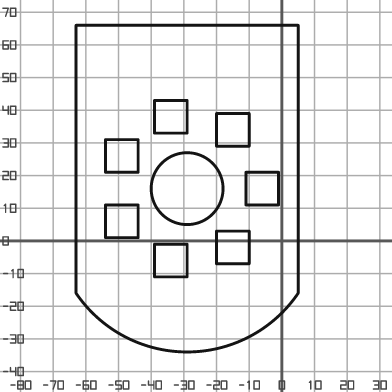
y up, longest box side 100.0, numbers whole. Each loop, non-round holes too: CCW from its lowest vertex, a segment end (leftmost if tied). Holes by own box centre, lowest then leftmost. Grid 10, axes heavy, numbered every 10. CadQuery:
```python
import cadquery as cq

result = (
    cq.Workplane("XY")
    .moveTo(-63.0, -16.0)
    .threePointArc((-29.0, -34.0), (5.0, -16.0))
    .lineTo(5.0, 66.0)
    .lineTo(-63.0, 66.0)
    .close()
    .moveTo(-39.0, -11.0)
    .lineTo(-29.0, -11.0)
    .lineTo(-29.0, -1.0)
    .lineTo(-39.0, -1.0)
    .close()
    .moveTo(-20.0, -7.0)
    .lineTo(-10.0, -7.0)
    .lineTo(-10.0, 3.0)
    .lineTo(-20.0, 3.0)
    .close()
    .moveTo(-54.0, 1.0)
    .lineTo(-44.0, 1.0)
    .lineTo(-44.0, 11.0)
    .lineTo(-54.0, 11.0)
    .close()
    .moveTo(-29.0, 16.0)
    .circle(11.0)
    .moveTo(-11.0, 11.0)
    .lineTo(-1.0, 11.0)
    .lineTo(-1.0, 21.0)
    .lineTo(-11.0, 21.0)
    .close()
    .moveTo(-54.0, 21.0)
    .lineTo(-44.0, 21.0)
    .lineTo(-44.0, 31.0)
    .lineTo(-54.0, 31.0)
    .close()
    .moveTo(-20.0, 29.0)
    .lineTo(-10.0, 29.0)
    .lineTo(-10.0, 39.0)
    .lineTo(-20.0, 39.0)
    .close()
    .moveTo(-39.0, 33.0)
    .lineTo(-29.0, 33.0)
    .lineTo(-29.0, 43.0)
    .lineTo(-39.0, 43.0)
    .close()
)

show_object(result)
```